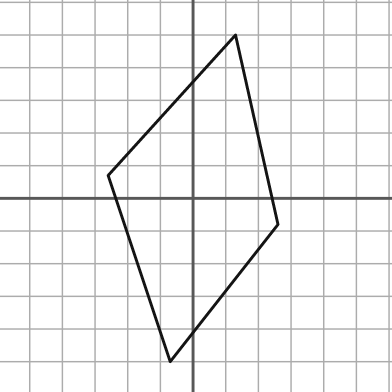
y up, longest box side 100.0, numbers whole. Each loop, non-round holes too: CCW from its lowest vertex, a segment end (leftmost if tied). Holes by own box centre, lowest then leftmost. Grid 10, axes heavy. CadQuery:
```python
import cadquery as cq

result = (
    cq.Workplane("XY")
    .moveTo(-7.0, -50.0)
    .lineTo(26.0, -8.0)
    .lineTo(13.0, 50.0)
    .lineTo(-26.0, 7.0)
    .close()
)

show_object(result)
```